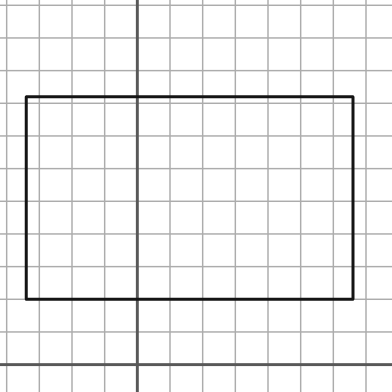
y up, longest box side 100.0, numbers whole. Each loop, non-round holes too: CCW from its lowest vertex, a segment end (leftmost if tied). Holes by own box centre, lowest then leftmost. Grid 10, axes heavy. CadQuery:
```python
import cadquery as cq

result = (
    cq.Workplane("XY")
    .moveTo(-34.0, 20.0)
    .lineTo(66.0, 20.0)
    .lineTo(66.0, 82.0)
    .lineTo(-34.0, 82.0)
    .close()
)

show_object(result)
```